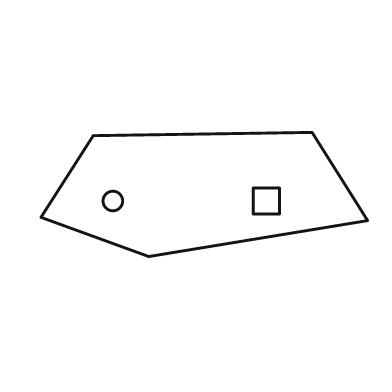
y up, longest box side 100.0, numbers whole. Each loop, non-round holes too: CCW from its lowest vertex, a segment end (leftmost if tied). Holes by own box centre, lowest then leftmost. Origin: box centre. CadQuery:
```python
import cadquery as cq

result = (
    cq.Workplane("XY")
    .moveTo(-17.0, -19.0)
    .lineTo(50.0, -8.0)
    .lineTo(33.0, 19.0)
    .lineTo(-34.0, 18.0)
    .lineTo(-50.0, -7.0)
    .close()
    .moveTo(-28.0, -2.0)
    .circle(3.0)
    .moveTo(15.0, -6.0)
    .lineTo(23.0, -6.0)
    .lineTo(23.0, 2.0)
    .lineTo(15.0, 2.0)
    .close()
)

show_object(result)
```